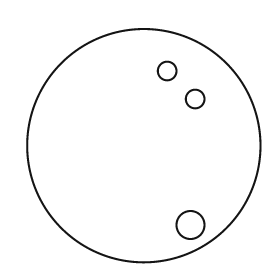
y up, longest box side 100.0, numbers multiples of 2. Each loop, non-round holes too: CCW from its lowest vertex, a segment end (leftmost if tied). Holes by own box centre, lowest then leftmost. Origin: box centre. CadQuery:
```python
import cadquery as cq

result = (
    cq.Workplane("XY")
    .moveTo(0.0, 0.0)
    .circle(50.0)
    .moveTo(20.0, -34.0)
    .circle(6.0)
    .moveTo(22.0, 20.0)
    .circle(4.0)
    .moveTo(10.0, 32.0)
    .circle(4.0)
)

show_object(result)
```